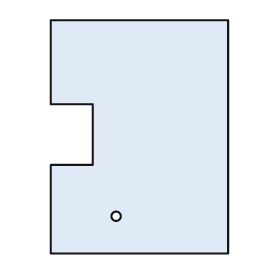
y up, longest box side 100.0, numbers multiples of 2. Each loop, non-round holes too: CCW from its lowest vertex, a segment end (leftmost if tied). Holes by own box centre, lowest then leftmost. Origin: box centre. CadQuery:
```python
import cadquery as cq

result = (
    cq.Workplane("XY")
    .moveTo(-38.0, -50.0)
    .lineTo(38.0, -50.0)
    .lineTo(38.0, 50.0)
    .lineTo(-38.0, 50.0)
    .lineTo(-38.0, 14.0)
    .lineTo(-20.0, 14.0)
    .lineTo(-20.0, -12.0)
    .lineTo(-38.0, -12.0)
    .close()
    .moveTo(-10.0, -34.0)
    .circle(2.0)
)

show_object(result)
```